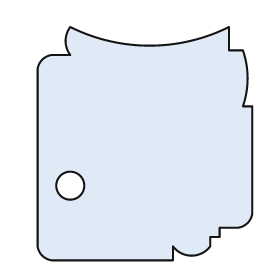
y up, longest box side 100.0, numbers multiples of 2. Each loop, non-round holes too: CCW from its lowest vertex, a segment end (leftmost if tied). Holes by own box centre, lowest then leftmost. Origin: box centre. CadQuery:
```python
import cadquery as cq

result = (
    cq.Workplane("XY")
    .moveTo(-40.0, -50.0)
    .lineTo(12.0, -50.0)
    .lineTo(12.0, -44.0)
    .threePointArc((20.0, -48.0), (28.0, -44.0))
    .lineTo(28.0, -40.0)
    .lineTo(32.0, -40.0)
    .lineTo(32.0, -36.0)
    .lineTo(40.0, -36.0)
    .threePointArc((44.0, -34.0), (46.0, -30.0))
    .lineTo(46.0, 16.0)
    .lineTo(42.0, 16.0)
    .threePointArc((44.0, 28.0), (42.0, 40.0))
    .lineTo(36.0, 40.0)
    .lineTo(36.0, 50.0)
    .threePointArc((2.0, 42.0), (-32.0, 50.0))
    .threePointArc((-34.0, 44.0), (-32.0, 38.0))
    .lineTo(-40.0, 38.0)
    .threePointArc((-44.0, 36.0), (-46.0, 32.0))
    .lineTo(-46.0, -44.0)
    .threePointArc((-44.0, -48.0), (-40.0, -50.0))
    .close()
    .moveTo(-32.0, -18.0)
    .circle(6.0)
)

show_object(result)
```